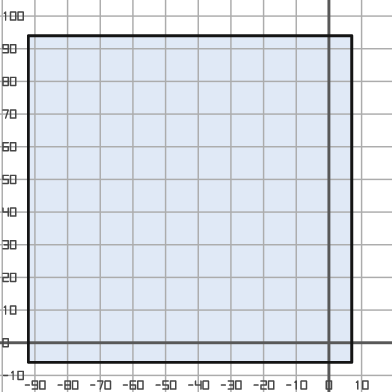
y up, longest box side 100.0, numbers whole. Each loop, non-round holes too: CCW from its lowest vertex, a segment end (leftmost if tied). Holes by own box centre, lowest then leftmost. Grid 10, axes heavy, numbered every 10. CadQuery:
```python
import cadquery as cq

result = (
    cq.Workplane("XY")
    .moveTo(-92.0, -6.0)
    .lineTo(7.0, -6.0)
    .lineTo(7.0, 94.0)
    .lineTo(-92.0, 94.0)
    .close()
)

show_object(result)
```